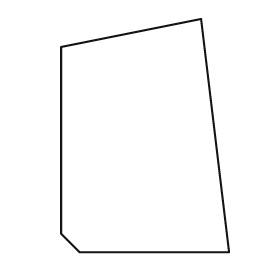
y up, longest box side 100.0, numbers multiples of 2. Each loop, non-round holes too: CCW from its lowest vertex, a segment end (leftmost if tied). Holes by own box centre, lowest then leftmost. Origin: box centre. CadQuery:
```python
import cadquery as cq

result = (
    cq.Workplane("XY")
    .moveTo(-28.0, -50.0)
    .lineTo(36.0, -50.0)
    .lineTo(24.0, 50.0)
    .lineTo(-36.0, 38.0)
    .lineTo(-36.0, -42.0)
    .close()
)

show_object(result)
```